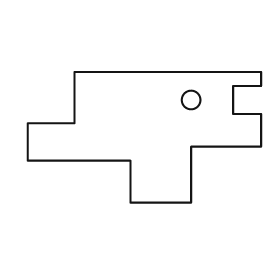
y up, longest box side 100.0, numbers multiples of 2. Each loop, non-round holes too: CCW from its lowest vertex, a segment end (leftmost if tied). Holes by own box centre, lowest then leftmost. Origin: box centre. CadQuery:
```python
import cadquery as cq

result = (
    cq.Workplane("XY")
    .moveTo(-6.0, -28.0)
    .lineTo(20.0, -28.0)
    .lineTo(20.0, -4.0)
    .lineTo(50.0, -4.0)
    .lineTo(50.0, 10.0)
    .lineTo(38.0, 10.0)
    .lineTo(38.0, 22.0)
    .lineTo(50.0, 22.0)
    .lineTo(50.0, 28.0)
    .lineTo(-30.0, 28.0)
    .lineTo(-30.0, 6.0)
    .lineTo(-50.0, 6.0)
    .lineTo(-50.0, -10.0)
    .lineTo(-6.0, -10.0)
    .close()
    .moveTo(20.0, 16.0)
    .circle(4.0)
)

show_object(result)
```